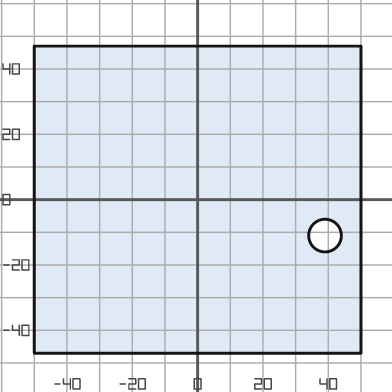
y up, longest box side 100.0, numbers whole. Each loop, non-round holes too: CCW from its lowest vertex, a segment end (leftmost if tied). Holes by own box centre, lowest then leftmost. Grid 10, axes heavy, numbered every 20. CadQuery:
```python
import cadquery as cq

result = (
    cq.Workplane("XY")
    .moveTo(-50.0, -47.0)
    .lineTo(50.0, -47.0)
    .lineTo(50.0, 47.0)
    .lineTo(-50.0, 47.0)
    .close()
    .moveTo(39.0, -11.0)
    .circle(5.0)
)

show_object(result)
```